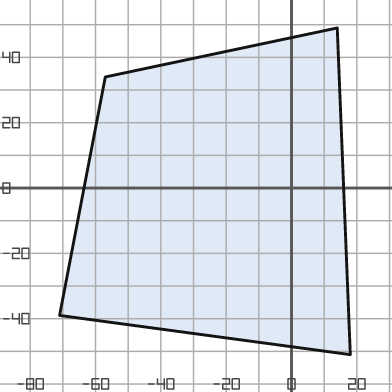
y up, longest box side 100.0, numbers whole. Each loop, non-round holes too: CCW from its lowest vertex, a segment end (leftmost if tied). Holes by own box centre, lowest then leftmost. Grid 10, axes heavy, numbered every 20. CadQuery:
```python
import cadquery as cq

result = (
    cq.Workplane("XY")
    .moveTo(18.0, -51.0)
    .lineTo(14.0, 49.0)
    .lineTo(-57.0, 34.0)
    .lineTo(-71.0, -39.0)
    .close()
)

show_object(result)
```